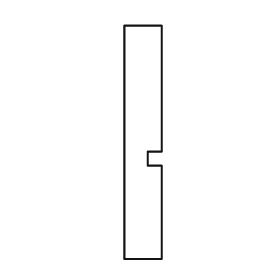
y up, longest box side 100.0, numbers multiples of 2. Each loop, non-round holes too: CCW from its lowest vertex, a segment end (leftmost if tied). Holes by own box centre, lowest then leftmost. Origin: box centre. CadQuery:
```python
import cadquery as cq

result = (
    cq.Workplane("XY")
    .moveTo(-8.0, -50.0)
    .lineTo(8.0, -50.0)
    .lineTo(8.0, -10.0)
    .lineTo(2.0, -10.0)
    .lineTo(2.0, -4.0)
    .lineTo(8.0, -4.0)
    .lineTo(8.0, 50.0)
    .lineTo(-8.0, 50.0)
    .close()
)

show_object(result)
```